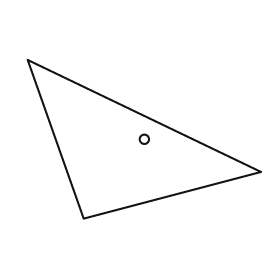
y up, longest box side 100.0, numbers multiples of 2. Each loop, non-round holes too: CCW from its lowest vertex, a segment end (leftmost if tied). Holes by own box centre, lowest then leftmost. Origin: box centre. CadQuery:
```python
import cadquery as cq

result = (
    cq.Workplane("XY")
    .moveTo(-26.0, -34.0)
    .lineTo(50.0, -14.0)
    .lineTo(-50.0, 34.0)
    .close()
    .moveTo(0.0, 0.0)
    .circle(2.0)
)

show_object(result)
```